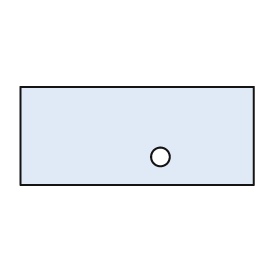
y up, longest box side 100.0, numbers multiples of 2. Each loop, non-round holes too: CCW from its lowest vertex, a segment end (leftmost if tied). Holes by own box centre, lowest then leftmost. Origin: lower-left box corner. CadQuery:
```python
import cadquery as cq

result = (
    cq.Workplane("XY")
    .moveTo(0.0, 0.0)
    .lineTo(100.0, 0.0)
    .lineTo(100.0, 42.0)
    .lineTo(0.0, 42.0)
    .close()
    .moveTo(60.0, 12.0)
    .circle(4.0)
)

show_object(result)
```